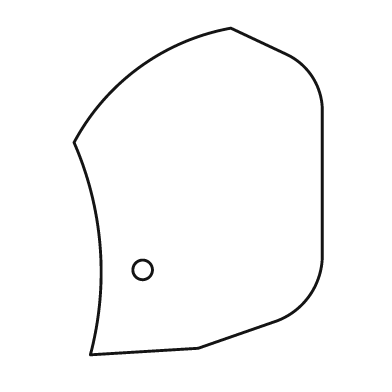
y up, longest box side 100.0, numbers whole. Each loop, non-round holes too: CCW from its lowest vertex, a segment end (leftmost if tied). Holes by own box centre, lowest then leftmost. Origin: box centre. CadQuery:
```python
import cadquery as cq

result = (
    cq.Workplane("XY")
    .moveTo(-33.0, -50.0)
    .lineTo(0.0, -48.0)
    .lineTo(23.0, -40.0)
    .threePointArc((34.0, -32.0), (38.0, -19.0))
    .lineTo(38.0, 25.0)
    .threePointArc((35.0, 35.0), (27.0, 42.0))
    .lineTo(10.0, 50.0)
    .threePointArc((-18.0, 38.0), (-38.0, 15.0))
    .threePointArc((-30.0, -17.0), (-33.0, -50.0))
    .close()
    .moveTo(-17.0, -24.0)
    .circle(3.0)
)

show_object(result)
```